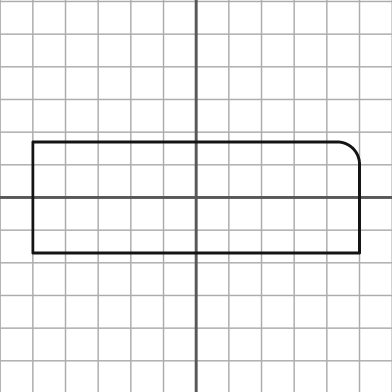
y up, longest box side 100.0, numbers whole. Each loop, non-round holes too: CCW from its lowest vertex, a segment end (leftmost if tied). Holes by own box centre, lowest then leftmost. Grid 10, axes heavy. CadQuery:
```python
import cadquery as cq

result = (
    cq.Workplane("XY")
    .moveTo(-50.0, -17.0)
    .lineTo(50.0, -17.0)
    .lineTo(50.0, 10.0)
    .threePointArc((48.0, 15.0), (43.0, 17.0))
    .lineTo(-50.0, 17.0)
    .close()
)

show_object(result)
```